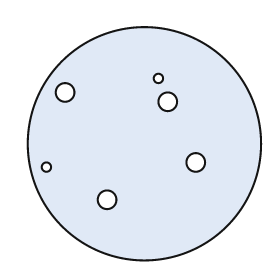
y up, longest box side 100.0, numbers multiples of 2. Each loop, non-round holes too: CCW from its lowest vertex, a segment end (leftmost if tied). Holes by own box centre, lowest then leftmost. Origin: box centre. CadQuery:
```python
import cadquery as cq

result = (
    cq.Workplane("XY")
    .moveTo(0.0, 0.0)
    .circle(50.0)
    .moveTo(-16.0, -24.0)
    .circle(4.0)
    .moveTo(-42.0, -10.0)
    .circle(2.0)
    .moveTo(22.0, -8.0)
    .circle(4.0)
    .moveTo(10.0, 18.0)
    .circle(4.0)
    .moveTo(-34.0, 22.0)
    .circle(4.0)
    .moveTo(6.0, 28.0)
    .circle(2.0)
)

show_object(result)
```